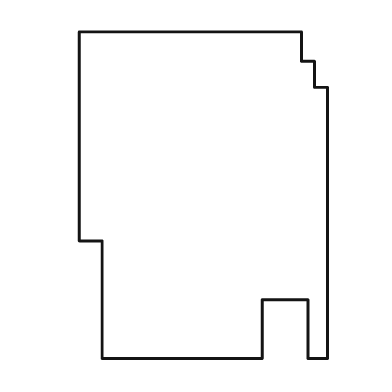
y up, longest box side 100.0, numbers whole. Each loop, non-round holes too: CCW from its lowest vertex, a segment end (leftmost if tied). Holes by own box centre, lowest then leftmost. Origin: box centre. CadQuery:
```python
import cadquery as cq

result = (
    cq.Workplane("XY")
    .moveTo(-31.0, -50.0)
    .lineTo(18.0, -50.0)
    .lineTo(18.0, -32.0)
    .lineTo(32.0, -32.0)
    .lineTo(32.0, -50.0)
    .lineTo(38.0, -50.0)
    .lineTo(38.0, 33.0)
    .lineTo(34.0, 33.0)
    .lineTo(34.0, 41.0)
    .lineTo(30.0, 41.0)
    .lineTo(30.0, 50.0)
    .lineTo(-38.0, 50.0)
    .lineTo(-38.0, -14.0)
    .lineTo(-31.0, -14.0)
    .close()
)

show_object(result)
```